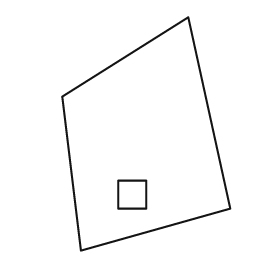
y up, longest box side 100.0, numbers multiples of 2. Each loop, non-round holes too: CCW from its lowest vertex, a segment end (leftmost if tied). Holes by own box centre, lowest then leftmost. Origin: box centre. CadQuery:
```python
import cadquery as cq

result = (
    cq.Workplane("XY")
    .moveTo(-28.0, -50.0)
    .lineTo(36.0, -32.0)
    .lineTo(18.0, 50.0)
    .lineTo(-36.0, 16.0)
    .close()
    .moveTo(-12.0, -32.0)
    .lineTo(0.0, -32.0)
    .lineTo(0.0, -20.0)
    .lineTo(-12.0, -20.0)
    .close()
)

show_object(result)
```